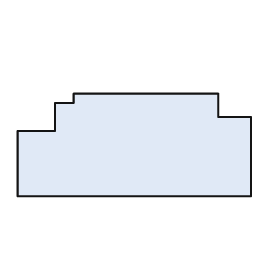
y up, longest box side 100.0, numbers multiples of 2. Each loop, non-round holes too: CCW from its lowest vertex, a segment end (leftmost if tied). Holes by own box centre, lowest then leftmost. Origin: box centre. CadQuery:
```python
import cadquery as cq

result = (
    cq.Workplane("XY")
    .moveTo(-50.0, -22.0)
    .lineTo(50.0, -22.0)
    .lineTo(50.0, 12.0)
    .lineTo(36.0, 12.0)
    .lineTo(36.0, 22.0)
    .lineTo(-26.0, 22.0)
    .lineTo(-26.0, 18.0)
    .lineTo(-34.0, 18.0)
    .lineTo(-34.0, 6.0)
    .lineTo(-50.0, 6.0)
    .close()
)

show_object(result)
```